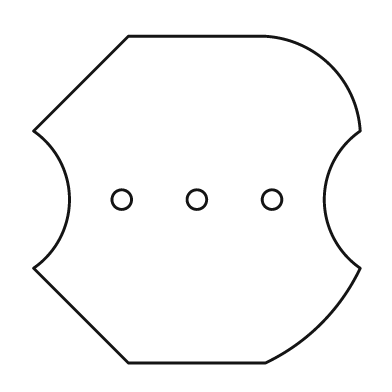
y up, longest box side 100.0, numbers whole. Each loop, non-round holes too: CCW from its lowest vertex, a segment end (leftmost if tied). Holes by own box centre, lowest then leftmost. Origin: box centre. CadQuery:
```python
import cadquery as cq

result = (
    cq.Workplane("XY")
    .moveTo(-21.0, -50.0)
    .lineTo(21.0, -50.0)
    .threePointArc((38.0, -38.0), (50.0, -21.0))
    .threePointArc((39.0, 0.0), (50.0, 21.0))
    .threePointArc((41.0, 41.0), (21.0, 50.0))
    .lineTo(-21.0, 50.0)
    .lineTo(-50.0, 21.0)
    .threePointArc((-39.0, 0.0), (-50.0, -21.0))
    .close()
    .moveTo(-23.0, 0.0)
    .circle(3.0)
    .moveTo(0.0, 0.0)
    .circle(3.0)
    .moveTo(23.0, 0.0)
    .circle(3.0)
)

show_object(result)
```